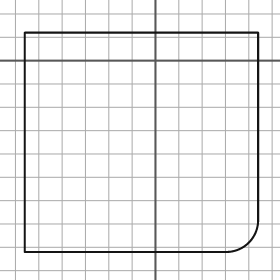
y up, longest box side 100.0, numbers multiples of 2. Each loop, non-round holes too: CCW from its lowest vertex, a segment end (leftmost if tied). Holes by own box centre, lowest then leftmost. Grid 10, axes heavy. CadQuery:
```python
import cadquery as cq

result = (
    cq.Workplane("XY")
    .moveTo(-56.0, -82.0)
    .lineTo(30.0, -82.0)
    .threePointArc((40.0, -78.0), (44.0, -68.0))
    .lineTo(44.0, 12.0)
    .lineTo(-56.0, 12.0)
    .close()
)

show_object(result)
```